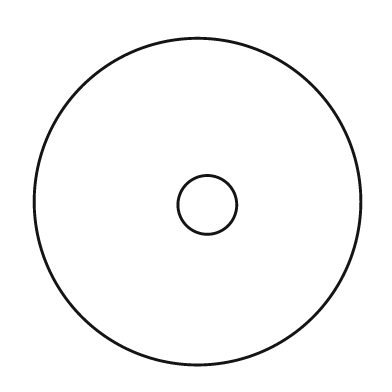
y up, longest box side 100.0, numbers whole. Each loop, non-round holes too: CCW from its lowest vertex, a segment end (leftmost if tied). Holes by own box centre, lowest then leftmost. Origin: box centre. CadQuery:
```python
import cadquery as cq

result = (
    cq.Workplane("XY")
    .moveTo(0.0, 0.0)
    .circle(50.0)
    .moveTo(3.0, -1.0)
    .circle(9.0)
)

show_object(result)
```